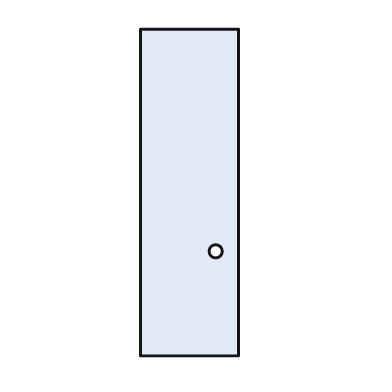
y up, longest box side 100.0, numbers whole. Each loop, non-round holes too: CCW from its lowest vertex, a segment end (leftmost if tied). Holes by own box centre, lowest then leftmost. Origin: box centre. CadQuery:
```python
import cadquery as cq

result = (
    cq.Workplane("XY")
    .moveTo(-15.0, -50.0)
    .lineTo(15.0, -50.0)
    .lineTo(15.0, 50.0)
    .lineTo(-15.0, 50.0)
    .close()
    .moveTo(8.0, -18.0)
    .circle(2.0)
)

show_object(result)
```